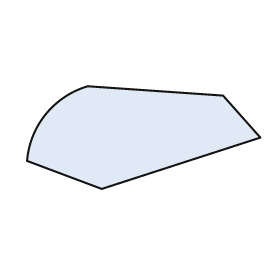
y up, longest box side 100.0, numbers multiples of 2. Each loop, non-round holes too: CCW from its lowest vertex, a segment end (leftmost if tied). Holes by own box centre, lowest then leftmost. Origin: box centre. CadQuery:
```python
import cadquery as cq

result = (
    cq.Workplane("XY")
    .moveTo(-18.0, -22.0)
    .lineTo(50.0, 0.0)
    .lineTo(34.0, 18.0)
    .lineTo(-24.0, 22.0)
    .threePointArc((-42.0, 10.0), (-50.0, -10.0))
    .close()
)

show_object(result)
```